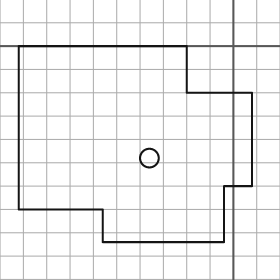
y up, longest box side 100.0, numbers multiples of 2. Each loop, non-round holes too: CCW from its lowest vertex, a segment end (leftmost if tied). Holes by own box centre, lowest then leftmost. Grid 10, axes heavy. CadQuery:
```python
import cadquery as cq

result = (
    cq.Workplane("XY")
    .moveTo(-56.0, -84.0)
    .lineTo(-4.0, -84.0)
    .lineTo(-4.0, -60.0)
    .lineTo(8.0, -60.0)
    .lineTo(8.0, -20.0)
    .lineTo(-20.0, -20.0)
    .lineTo(-20.0, 0.0)
    .lineTo(-92.0, 0.0)
    .lineTo(-92.0, -70.0)
    .lineTo(-56.0, -70.0)
    .close()
    .moveTo(-36.0, -48.0)
    .circle(4.0)
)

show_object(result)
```